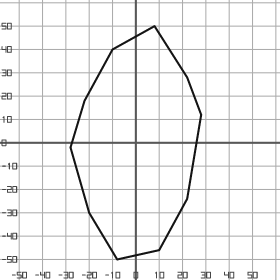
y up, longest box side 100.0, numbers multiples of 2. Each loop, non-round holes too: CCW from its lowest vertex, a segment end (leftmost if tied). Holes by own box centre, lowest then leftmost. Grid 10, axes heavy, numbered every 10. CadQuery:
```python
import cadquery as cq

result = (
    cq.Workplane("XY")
    .moveTo(-8.0, -50.0)
    .lineTo(10.0, -46.0)
    .lineTo(22.0, -24.0)
    .lineTo(28.0, 12.0)
    .lineTo(22.0, 28.0)
    .lineTo(8.0, 50.0)
    .lineTo(-10.0, 40.0)
    .lineTo(-22.0, 18.0)
    .lineTo(-28.0, -2.0)
    .lineTo(-20.0, -30.0)
    .close()
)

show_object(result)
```